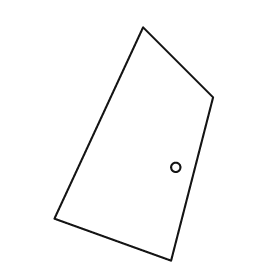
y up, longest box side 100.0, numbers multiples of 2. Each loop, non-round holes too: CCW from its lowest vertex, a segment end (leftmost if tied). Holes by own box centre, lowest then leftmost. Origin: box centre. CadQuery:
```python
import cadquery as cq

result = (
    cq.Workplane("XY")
    .moveTo(16.0, -50.0)
    .lineTo(34.0, 20.0)
    .lineTo(4.0, 50.0)
    .lineTo(-34.0, -32.0)
    .close()
    .moveTo(18.0, -10.0)
    .circle(2.0)
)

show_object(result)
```